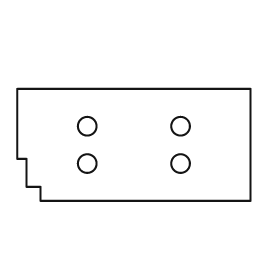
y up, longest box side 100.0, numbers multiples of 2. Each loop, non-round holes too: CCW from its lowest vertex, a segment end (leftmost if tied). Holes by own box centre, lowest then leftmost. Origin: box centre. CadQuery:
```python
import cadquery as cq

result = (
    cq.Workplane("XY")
    .moveTo(-40.0, -24.0)
    .lineTo(50.0, -24.0)
    .lineTo(50.0, 24.0)
    .lineTo(-50.0, 24.0)
    .lineTo(-50.0, -6.0)
    .lineTo(-46.0, -6.0)
    .lineTo(-46.0, -18.0)
    .lineTo(-40.0, -18.0)
    .close()
    .moveTo(-20.0, -8.0)
    .circle(4.0)
    .moveTo(20.0, -8.0)
    .circle(4.0)
    .moveTo(-20.0, 8.0)
    .circle(4.0)
    .moveTo(20.0, 8.0)
    .circle(4.0)
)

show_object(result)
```